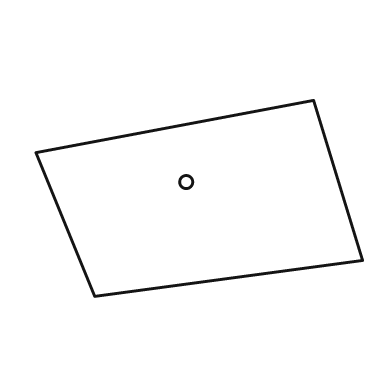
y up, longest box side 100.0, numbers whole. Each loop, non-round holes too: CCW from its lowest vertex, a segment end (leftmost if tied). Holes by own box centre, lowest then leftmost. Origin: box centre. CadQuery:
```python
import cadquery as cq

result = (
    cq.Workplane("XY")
    .moveTo(-32.0, -30.0)
    .lineTo(50.0, -19.0)
    .lineTo(35.0, 30.0)
    .lineTo(-50.0, 14.0)
    .close()
    .moveTo(-4.0, 5.0)
    .circle(2.0)
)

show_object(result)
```